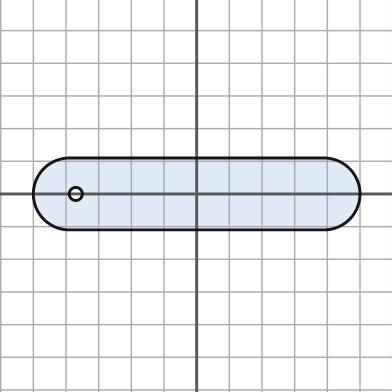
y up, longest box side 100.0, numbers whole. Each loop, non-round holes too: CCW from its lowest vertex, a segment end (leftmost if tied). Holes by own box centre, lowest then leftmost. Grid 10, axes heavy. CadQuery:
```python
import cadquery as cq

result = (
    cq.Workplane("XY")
    .moveTo(-39.0, -11.0)
    .lineTo(39.0, -11.0)
    .threePointArc((50.0, 0.0), (39.0, 11.0))
    .lineTo(-39.0, 11.0)
    .threePointArc((-50.0, 0.0), (-39.0, -11.0))
    .close()
    .moveTo(-37.0, 0.0)
    .circle(2.0)
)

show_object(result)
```